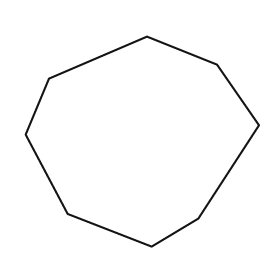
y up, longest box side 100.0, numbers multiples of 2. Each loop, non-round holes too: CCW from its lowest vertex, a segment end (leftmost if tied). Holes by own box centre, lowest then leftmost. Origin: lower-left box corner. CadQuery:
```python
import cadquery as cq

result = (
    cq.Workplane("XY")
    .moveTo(54.0, 0.0)
    .lineTo(74.0, 12.0)
    .lineTo(100.0, 52.0)
    .lineTo(82.0, 78.0)
    .lineTo(52.0, 90.0)
    .lineTo(10.0, 72.0)
    .lineTo(0.0, 48.0)
    .lineTo(18.0, 14.0)
    .close()
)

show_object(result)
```